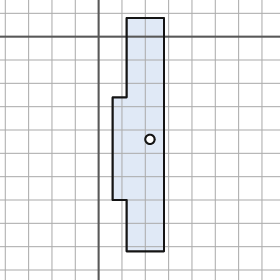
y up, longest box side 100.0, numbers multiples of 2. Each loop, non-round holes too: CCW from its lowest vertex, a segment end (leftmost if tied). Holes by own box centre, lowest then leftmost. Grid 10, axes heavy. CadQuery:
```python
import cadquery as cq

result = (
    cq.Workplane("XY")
    .moveTo(12.0, -92.0)
    .lineTo(28.0, -92.0)
    .lineTo(28.0, 8.0)
    .lineTo(12.0, 8.0)
    .lineTo(12.0, -26.0)
    .lineTo(6.0, -26.0)
    .lineTo(6.0, -70.0)
    .lineTo(12.0, -70.0)
    .close()
    .moveTo(22.0, -44.0)
    .circle(2.0)
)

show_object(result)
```